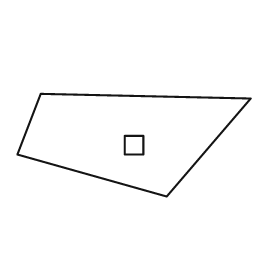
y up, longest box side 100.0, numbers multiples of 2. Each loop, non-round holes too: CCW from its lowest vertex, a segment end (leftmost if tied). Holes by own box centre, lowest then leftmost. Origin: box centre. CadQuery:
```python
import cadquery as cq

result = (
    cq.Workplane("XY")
    .moveTo(14.0, -22.0)
    .lineTo(50.0, 20.0)
    .lineTo(-40.0, 22.0)
    .lineTo(-50.0, -4.0)
    .close()
    .moveTo(-4.0, -4.0)
    .lineTo(4.0, -4.0)
    .lineTo(4.0, 4.0)
    .lineTo(-4.0, 4.0)
    .close()
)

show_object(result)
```